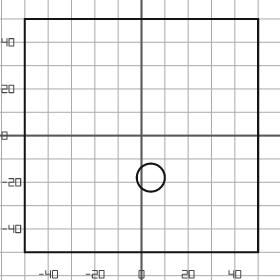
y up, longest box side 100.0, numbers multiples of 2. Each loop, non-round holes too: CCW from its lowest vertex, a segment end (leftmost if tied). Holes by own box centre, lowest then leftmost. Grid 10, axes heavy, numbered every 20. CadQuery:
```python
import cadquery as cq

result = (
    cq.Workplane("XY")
    .moveTo(-50.0, -50.0)
    .lineTo(50.0, -50.0)
    .lineTo(50.0, 50.0)
    .lineTo(-50.0, 50.0)
    .close()
    .moveTo(4.0, -18.0)
    .circle(6.0)
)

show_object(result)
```